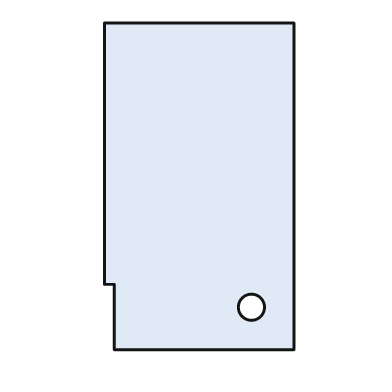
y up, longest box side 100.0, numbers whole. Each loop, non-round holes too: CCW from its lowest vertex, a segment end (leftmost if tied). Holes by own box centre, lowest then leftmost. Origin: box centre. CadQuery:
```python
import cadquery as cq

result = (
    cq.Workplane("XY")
    .moveTo(-26.0, -50.0)
    .lineTo(29.0, -50.0)
    .lineTo(29.0, 50.0)
    .lineTo(-29.0, 50.0)
    .lineTo(-29.0, -30.0)
    .lineTo(-26.0, -30.0)
    .close()
    .moveTo(16.0, -37.0)
    .circle(4.0)
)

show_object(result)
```